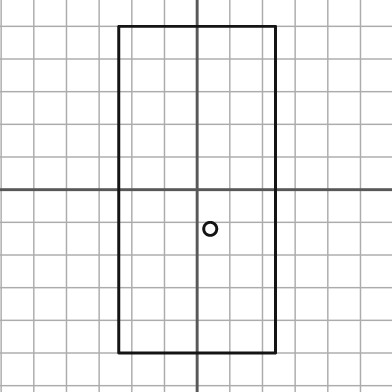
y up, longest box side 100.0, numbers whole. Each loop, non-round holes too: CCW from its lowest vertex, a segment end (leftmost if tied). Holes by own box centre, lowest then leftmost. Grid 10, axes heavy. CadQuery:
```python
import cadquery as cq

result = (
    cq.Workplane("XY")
    .moveTo(-24.0, -50.0)
    .lineTo(24.0, -50.0)
    .lineTo(24.0, 50.0)
    .lineTo(-24.0, 50.0)
    .close()
    .moveTo(4.0, -12.0)
    .circle(2.0)
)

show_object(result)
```